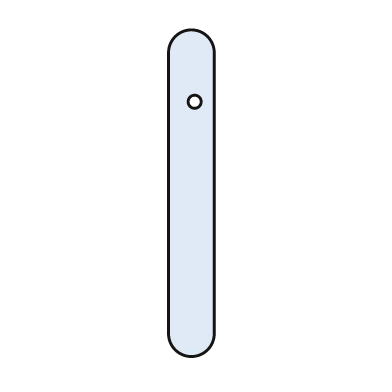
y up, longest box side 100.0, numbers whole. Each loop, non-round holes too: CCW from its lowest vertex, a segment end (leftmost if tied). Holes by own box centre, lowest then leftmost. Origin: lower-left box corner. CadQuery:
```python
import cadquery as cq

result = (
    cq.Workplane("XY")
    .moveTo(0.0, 7.0)
    .threePointArc((7.0, 0.0), (14.0, 7.0))
    .lineTo(14.0, 93.0)
    .threePointArc((7.0, 100.0), (0.0, 93.0))
    .close()
    .moveTo(8.0, 78.0)
    .circle(2.0)
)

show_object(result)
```